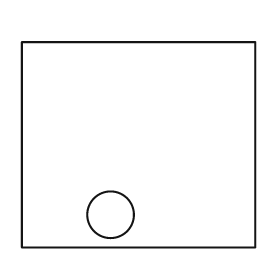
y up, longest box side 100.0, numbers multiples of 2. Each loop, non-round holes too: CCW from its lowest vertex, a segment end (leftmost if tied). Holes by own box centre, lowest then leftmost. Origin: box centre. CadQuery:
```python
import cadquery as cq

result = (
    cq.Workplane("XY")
    .moveTo(-50.0, -44.0)
    .lineTo(50.0, -44.0)
    .lineTo(50.0, 44.0)
    .lineTo(-50.0, 44.0)
    .close()
    .moveTo(-12.0, -30.0)
    .circle(10.0)
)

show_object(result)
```